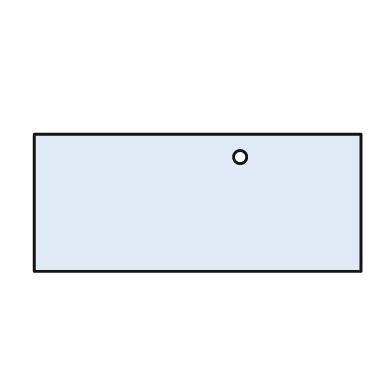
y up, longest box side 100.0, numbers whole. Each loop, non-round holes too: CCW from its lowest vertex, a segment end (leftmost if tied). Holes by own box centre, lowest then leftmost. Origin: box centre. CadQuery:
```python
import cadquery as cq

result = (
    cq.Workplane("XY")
    .moveTo(-50.0, -21.0)
    .lineTo(50.0, -21.0)
    .lineTo(50.0, 21.0)
    .lineTo(-50.0, 21.0)
    .close()
    .moveTo(13.0, 14.0)
    .circle(2.0)
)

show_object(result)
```